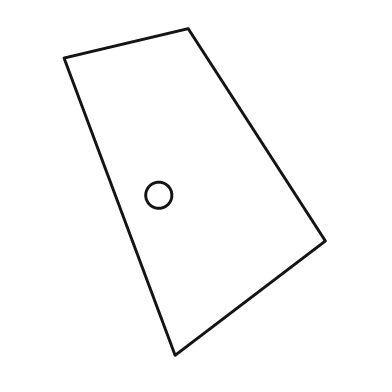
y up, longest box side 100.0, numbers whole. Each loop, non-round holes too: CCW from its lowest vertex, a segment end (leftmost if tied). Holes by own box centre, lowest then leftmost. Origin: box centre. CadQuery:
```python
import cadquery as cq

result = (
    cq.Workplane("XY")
    .moveTo(-6.0, -50.0)
    .lineTo(40.0, -15.0)
    .lineTo(-2.0, 50.0)
    .lineTo(-40.0, 41.0)
    .close()
    .moveTo(-11.0, -1.0)
    .circle(4.0)
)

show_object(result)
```